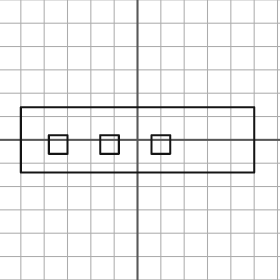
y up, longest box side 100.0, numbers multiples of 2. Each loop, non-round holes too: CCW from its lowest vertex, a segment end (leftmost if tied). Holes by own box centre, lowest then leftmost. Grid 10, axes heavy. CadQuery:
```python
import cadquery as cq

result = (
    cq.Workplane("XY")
    .moveTo(-50.0, -14.0)
    .lineTo(50.0, -14.0)
    .lineTo(50.0, 14.0)
    .lineTo(-50.0, 14.0)
    .close()
    .moveTo(-38.0, -6.0)
    .lineTo(-30.0, -6.0)
    .lineTo(-30.0, 2.0)
    .lineTo(-38.0, 2.0)
    .close()
    .moveTo(-16.0, -6.0)
    .lineTo(-8.0, -6.0)
    .lineTo(-8.0, 2.0)
    .lineTo(-16.0, 2.0)
    .close()
    .moveTo(6.0, -6.0)
    .lineTo(14.0, -6.0)
    .lineTo(14.0, 2.0)
    .lineTo(6.0, 2.0)
    .close()
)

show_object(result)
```